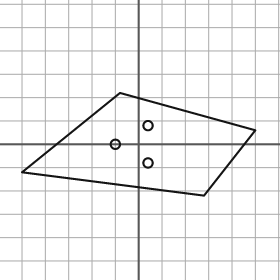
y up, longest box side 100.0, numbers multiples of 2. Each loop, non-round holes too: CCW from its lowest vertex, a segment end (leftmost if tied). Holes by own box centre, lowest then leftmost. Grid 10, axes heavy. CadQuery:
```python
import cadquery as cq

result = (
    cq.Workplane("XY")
    .moveTo(28.0, -22.0)
    .lineTo(50.0, 6.0)
    .lineTo(-8.0, 22.0)
    .lineTo(-50.0, -12.0)
    .close()
    .moveTo(4.0, -8.0)
    .circle(2.0)
    .moveTo(-10.0, 0.0)
    .circle(2.0)
    .moveTo(4.0, 8.0)
    .circle(2.0)
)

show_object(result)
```